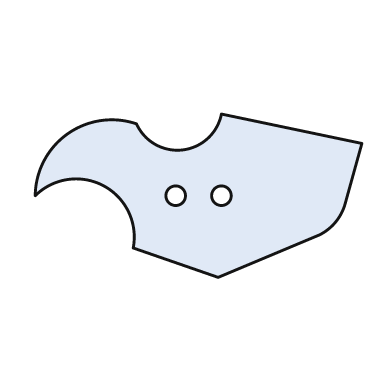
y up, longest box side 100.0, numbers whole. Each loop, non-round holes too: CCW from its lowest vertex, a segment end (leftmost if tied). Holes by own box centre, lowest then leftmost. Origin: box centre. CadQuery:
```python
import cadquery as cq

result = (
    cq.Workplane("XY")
    .moveTo(6.0, -25.0)
    .lineTo(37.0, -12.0)
    .threePointArc((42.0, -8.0), (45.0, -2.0))
    .lineTo(50.0, 16.0)
    .lineTo(7.0, 25.0)
    .threePointArc((-5.0, 14.0), (-19.0, 22.0))
    .threePointArc((-40.0, 19.0), (-50.0, 0.0))
    .threePointArc((-29.0, 3.0), (-20.0, -16.0))
    .close()
    .moveTo(-7.0, 0.0)
    .circle(3.0)
    .moveTo(7.0, 0.0)
    .circle(3.0)
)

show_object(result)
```